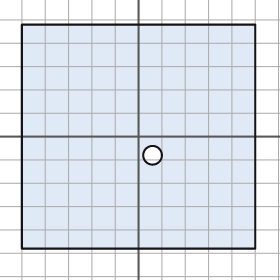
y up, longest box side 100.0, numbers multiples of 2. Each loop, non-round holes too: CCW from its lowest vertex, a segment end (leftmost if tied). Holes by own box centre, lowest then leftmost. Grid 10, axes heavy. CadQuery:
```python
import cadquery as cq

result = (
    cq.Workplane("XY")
    .moveTo(-50.0, -48.0)
    .lineTo(50.0, -48.0)
    .lineTo(50.0, 48.0)
    .lineTo(-50.0, 48.0)
    .close()
    .moveTo(6.0, -8.0)
    .circle(4.0)
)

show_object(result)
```